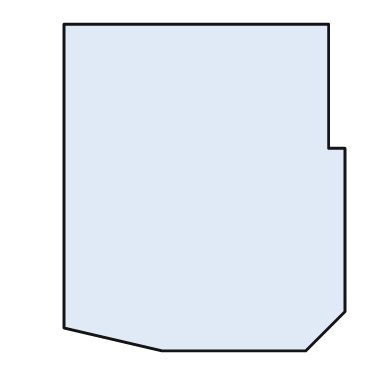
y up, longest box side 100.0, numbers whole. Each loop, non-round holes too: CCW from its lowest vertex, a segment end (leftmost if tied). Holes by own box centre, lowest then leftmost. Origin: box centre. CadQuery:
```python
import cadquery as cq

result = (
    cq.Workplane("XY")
    .moveTo(-13.0, -50.0)
    .lineTo(31.0, -50.0)
    .lineTo(43.0, -38.0)
    .lineTo(43.0, 12.0)
    .lineTo(38.0, 12.0)
    .lineTo(38.0, 50.0)
    .lineTo(-43.0, 50.0)
    .lineTo(-43.0, -43.0)
    .close()
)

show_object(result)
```